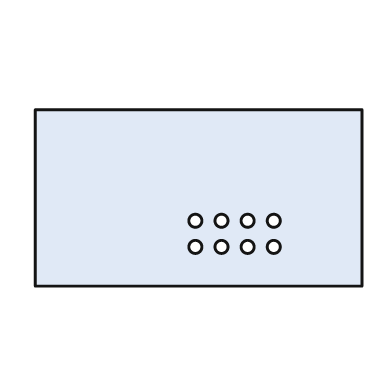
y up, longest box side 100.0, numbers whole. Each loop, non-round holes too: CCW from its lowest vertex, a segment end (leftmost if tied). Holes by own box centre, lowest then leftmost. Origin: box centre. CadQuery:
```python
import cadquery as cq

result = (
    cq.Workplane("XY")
    .moveTo(-50.0, -27.0)
    .lineTo(50.0, -27.0)
    .lineTo(50.0, 27.0)
    .lineTo(-50.0, 27.0)
    .close()
    .moveTo(-1.0, -15.0)
    .circle(2.0)
    .moveTo(7.0, -15.0)
    .circle(2.0)
    .moveTo(15.0, -15.0)
    .circle(2.0)
    .moveTo(23.0, -15.0)
    .circle(2.0)
    .moveTo(-1.0, -7.0)
    .circle(2.0)
    .moveTo(7.0, -7.0)
    .circle(2.0)
    .moveTo(15.0, -7.0)
    .circle(2.0)
    .moveTo(23.0, -7.0)
    .circle(2.0)
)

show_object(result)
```